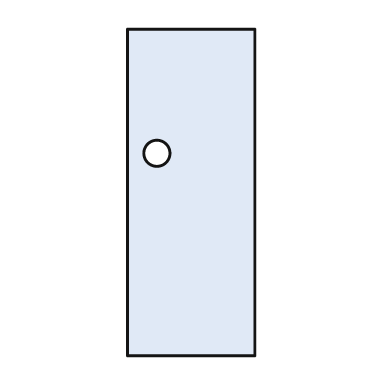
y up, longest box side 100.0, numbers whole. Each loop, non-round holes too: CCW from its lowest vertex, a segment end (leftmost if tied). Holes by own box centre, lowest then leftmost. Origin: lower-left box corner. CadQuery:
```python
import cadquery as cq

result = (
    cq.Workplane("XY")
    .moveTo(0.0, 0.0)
    .lineTo(39.0, 0.0)
    .lineTo(39.0, 100.0)
    .lineTo(0.0, 100.0)
    .close()
    .moveTo(9.0, 62.0)
    .circle(4.0)
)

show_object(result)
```